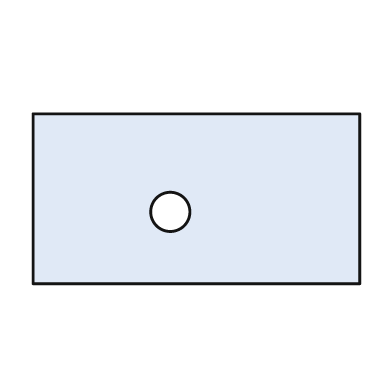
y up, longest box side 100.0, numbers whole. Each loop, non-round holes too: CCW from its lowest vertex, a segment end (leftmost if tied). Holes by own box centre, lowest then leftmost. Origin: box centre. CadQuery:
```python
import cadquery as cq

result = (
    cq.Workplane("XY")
    .moveTo(-50.0, -26.0)
    .lineTo(50.0, -26.0)
    .lineTo(50.0, 26.0)
    .lineTo(-50.0, 26.0)
    .close()
    .moveTo(-8.0, -4.0)
    .circle(6.0)
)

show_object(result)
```